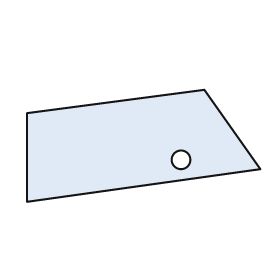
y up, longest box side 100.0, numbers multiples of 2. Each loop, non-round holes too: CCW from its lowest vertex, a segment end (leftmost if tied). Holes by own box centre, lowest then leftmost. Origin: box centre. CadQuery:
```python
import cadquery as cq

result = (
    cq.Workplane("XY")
    .moveTo(-50.0, -24.0)
    .lineTo(50.0, -10.0)
    .lineTo(26.0, 24.0)
    .lineTo(-50.0, 14.0)
    .close()
    .moveTo(16.0, -6.0)
    .circle(4.0)
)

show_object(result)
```